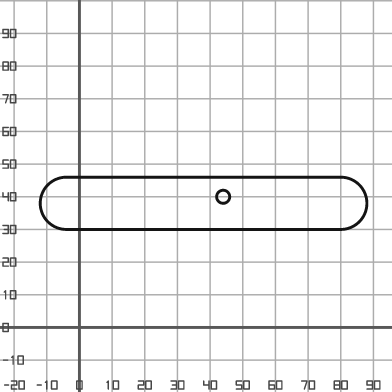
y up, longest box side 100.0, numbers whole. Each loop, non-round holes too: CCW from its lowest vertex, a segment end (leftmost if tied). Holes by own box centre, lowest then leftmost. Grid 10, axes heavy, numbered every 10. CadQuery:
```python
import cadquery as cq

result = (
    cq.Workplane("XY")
    .moveTo(-4.0, 30.0)
    .lineTo(80.0, 30.0)
    .threePointArc((88.0, 38.0), (80.0, 46.0))
    .lineTo(-4.0, 46.0)
    .threePointArc((-12.0, 38.0), (-4.0, 30.0))
    .close()
    .moveTo(44.0, 40.0)
    .circle(2.0)
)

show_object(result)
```